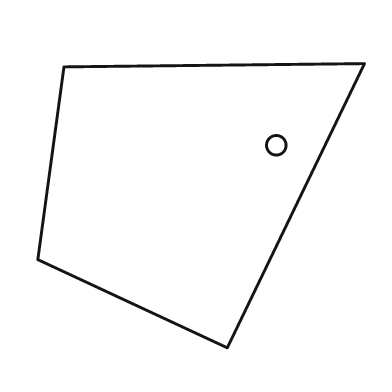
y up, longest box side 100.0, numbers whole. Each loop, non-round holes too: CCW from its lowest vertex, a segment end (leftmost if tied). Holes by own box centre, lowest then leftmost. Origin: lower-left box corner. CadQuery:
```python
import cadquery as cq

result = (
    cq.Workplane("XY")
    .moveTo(58.0, 0.0)
    .lineTo(100.0, 87.0)
    .lineTo(8.0, 86.0)
    .lineTo(0.0, 27.0)
    .close()
    .moveTo(73.0, 62.0)
    .circle(3.0)
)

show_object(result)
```